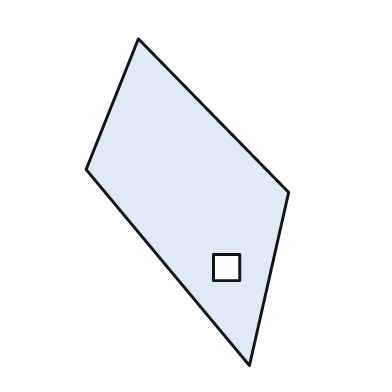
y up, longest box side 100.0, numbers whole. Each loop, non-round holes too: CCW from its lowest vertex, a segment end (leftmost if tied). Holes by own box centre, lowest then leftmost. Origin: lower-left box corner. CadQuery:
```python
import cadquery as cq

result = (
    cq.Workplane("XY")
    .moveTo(50.0, 0.0)
    .lineTo(62.0, 53.0)
    .lineTo(16.0, 100.0)
    .lineTo(0.0, 60.0)
    .close()
    .moveTo(39.0, 26.0)
    .lineTo(47.0, 26.0)
    .lineTo(47.0, 34.0)
    .lineTo(39.0, 34.0)
    .close()
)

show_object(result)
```